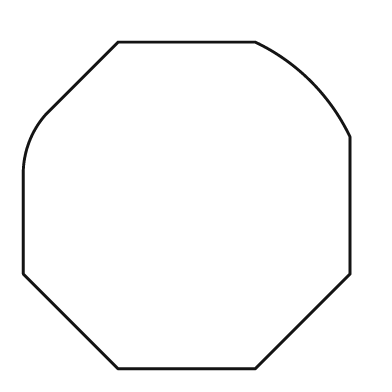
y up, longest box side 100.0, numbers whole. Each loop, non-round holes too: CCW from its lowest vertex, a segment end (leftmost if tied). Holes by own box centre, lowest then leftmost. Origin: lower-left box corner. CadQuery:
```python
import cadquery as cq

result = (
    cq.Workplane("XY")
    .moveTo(29.0, 0.0)
    .lineTo(71.0, 0.0)
    .lineTo(100.0, 29.0)
    .lineTo(100.0, 71.0)
    .threePointArc((88.0, 88.0), (71.0, 100.0))
    .lineTo(29.0, 100.0)
    .lineTo(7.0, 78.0)
    .threePointArc((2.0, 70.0), (0.0, 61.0))
    .lineTo(0.0, 29.0)
    .close()
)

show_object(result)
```